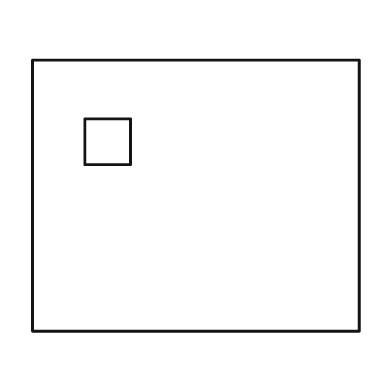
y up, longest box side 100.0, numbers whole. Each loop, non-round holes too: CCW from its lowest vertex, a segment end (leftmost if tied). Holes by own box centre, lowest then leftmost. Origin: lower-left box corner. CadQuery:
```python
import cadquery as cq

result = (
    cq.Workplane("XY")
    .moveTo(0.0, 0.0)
    .lineTo(100.0, 0.0)
    .lineTo(100.0, 83.0)
    .lineTo(0.0, 83.0)
    .close()
    .moveTo(16.0, 51.0)
    .lineTo(30.0, 51.0)
    .lineTo(30.0, 65.0)
    .lineTo(16.0, 65.0)
    .close()
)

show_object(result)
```